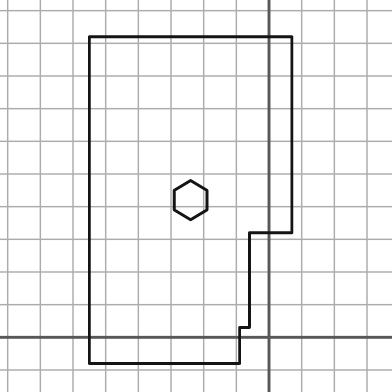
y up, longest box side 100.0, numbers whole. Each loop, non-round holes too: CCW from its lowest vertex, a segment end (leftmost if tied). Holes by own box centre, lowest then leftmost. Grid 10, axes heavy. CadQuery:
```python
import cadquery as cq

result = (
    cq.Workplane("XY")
    .moveTo(-55.0, -8.0)
    .lineTo(-9.0, -8.0)
    .lineTo(-9.0, 3.0)
    .lineTo(-6.0, 3.0)
    .lineTo(-6.0, 32.0)
    .lineTo(7.0, 32.0)
    .lineTo(7.0, 92.0)
    .lineTo(-55.0, 92.0)
    .close()
    .moveTo(-24.0, 36.0)
    .lineTo(-19.0, 39.0)
    .lineTo(-19.0, 45.0)
    .lineTo(-24.0, 48.0)
    .lineTo(-29.0, 45.0)
    .lineTo(-29.0, 39.0)
    .close()
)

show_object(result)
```